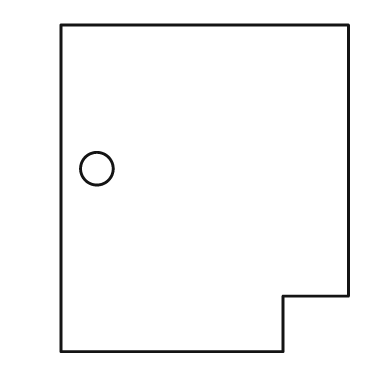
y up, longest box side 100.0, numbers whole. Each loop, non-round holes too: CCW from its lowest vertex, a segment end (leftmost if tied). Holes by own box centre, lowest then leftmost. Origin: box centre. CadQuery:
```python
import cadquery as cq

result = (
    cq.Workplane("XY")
    .moveTo(-44.0, -50.0)
    .lineTo(24.0, -50.0)
    .lineTo(24.0, -33.0)
    .lineTo(44.0, -33.0)
    .lineTo(44.0, 50.0)
    .lineTo(-44.0, 50.0)
    .close()
    .moveTo(-33.0, 6.0)
    .circle(5.0)
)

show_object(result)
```